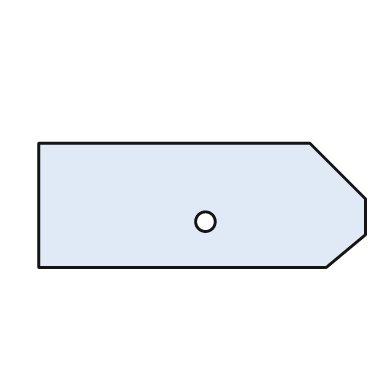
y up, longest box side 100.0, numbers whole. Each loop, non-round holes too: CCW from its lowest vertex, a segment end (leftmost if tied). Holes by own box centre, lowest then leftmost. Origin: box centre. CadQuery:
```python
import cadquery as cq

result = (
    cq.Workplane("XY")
    .moveTo(-50.0, -19.0)
    .lineTo(38.0, -19.0)
    .lineTo(50.0, -9.0)
    .lineTo(50.0, 2.0)
    .lineTo(33.0, 19.0)
    .lineTo(-50.0, 19.0)
    .close()
    .moveTo(1.0, -5.0)
    .circle(3.0)
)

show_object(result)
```